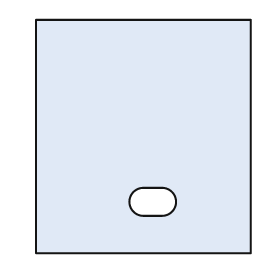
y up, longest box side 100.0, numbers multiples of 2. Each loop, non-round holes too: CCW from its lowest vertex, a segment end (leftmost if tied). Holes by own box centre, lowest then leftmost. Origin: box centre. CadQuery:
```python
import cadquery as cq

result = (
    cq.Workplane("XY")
    .moveTo(-46.0, -50.0)
    .lineTo(46.0, -50.0)
    .lineTo(46.0, 50.0)
    .lineTo(-46.0, 50.0)
    .close()
    .moveTo(0.0, -34.0)
    .lineTo(8.0, -34.0)
    .threePointArc((14.0, -28.0), (8.0, -22.0))
    .lineTo(0.0, -22.0)
    .threePointArc((-6.0, -28.0), (0.0, -34.0))
    .close()
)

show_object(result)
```